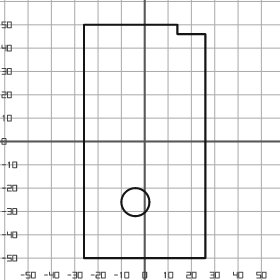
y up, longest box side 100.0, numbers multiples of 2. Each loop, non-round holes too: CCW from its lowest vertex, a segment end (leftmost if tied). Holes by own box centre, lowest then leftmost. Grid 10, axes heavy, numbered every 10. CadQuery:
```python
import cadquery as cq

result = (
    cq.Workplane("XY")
    .moveTo(-26.0, -50.0)
    .lineTo(26.0, -50.0)
    .lineTo(26.0, 46.0)
    .lineTo(14.0, 46.0)
    .lineTo(14.0, 50.0)
    .lineTo(-26.0, 50.0)
    .close()
    .moveTo(-4.0, -26.0)
    .circle(6.0)
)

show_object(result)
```